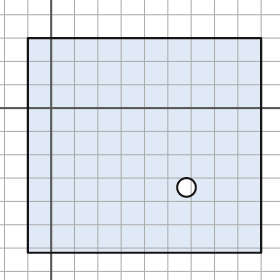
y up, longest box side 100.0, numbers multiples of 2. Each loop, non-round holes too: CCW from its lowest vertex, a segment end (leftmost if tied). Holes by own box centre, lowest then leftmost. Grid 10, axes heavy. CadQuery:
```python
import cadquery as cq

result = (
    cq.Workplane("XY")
    .moveTo(-10.0, -62.0)
    .lineTo(90.0, -62.0)
    .lineTo(90.0, 30.0)
    .lineTo(-10.0, 30.0)
    .close()
    .moveTo(58.0, -34.0)
    .circle(4.0)
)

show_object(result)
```